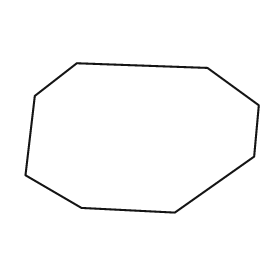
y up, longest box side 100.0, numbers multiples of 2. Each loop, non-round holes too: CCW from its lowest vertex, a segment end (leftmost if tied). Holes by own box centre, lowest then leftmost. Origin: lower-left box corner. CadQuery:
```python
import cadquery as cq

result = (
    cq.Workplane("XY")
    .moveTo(64.0, 0.0)
    .lineTo(98.0, 24.0)
    .lineTo(100.0, 46.0)
    .lineTo(78.0, 62.0)
    .lineTo(22.0, 64.0)
    .lineTo(4.0, 50.0)
    .lineTo(0.0, 16.0)
    .lineTo(24.0, 2.0)
    .close()
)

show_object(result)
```